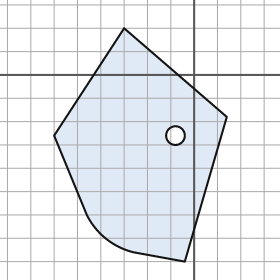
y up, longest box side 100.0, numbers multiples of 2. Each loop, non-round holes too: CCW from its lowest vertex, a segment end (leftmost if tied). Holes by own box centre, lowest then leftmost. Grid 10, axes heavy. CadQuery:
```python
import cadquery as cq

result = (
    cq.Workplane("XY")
    .moveTo(-4.0, -80.0)
    .lineTo(14.0, -18.0)
    .lineTo(-30.0, 20.0)
    .lineTo(-60.0, -26.0)
    .lineTo(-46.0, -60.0)
    .threePointArc((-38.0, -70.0), (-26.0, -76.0))
    .close()
    .moveTo(-8.0, -26.0)
    .circle(4.0)
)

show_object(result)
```